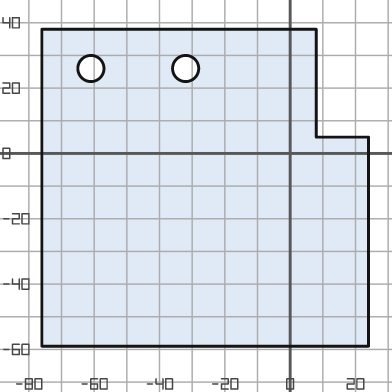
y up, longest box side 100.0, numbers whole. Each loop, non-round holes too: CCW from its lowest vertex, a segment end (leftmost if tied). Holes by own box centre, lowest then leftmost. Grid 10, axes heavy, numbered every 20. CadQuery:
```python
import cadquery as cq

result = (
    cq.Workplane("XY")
    .moveTo(-76.0, -59.0)
    .lineTo(24.0, -59.0)
    .lineTo(24.0, 5.0)
    .lineTo(8.0, 5.0)
    .lineTo(8.0, 38.0)
    .lineTo(-76.0, 38.0)
    .close()
    .moveTo(-61.0, 26.0)
    .circle(4.0)
    .moveTo(-32.0, 26.0)
    .circle(4.0)
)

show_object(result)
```